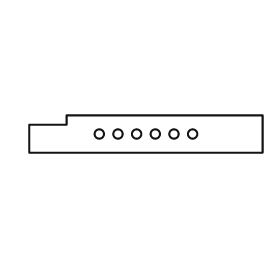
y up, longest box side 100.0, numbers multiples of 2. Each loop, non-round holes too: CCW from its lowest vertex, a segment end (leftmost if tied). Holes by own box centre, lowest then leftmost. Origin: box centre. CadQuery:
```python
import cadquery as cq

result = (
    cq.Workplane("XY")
    .moveTo(-50.0, -8.0)
    .lineTo(50.0, -8.0)
    .lineTo(50.0, 8.0)
    .lineTo(-34.0, 8.0)
    .lineTo(-34.0, 4.0)
    .lineTo(-50.0, 4.0)
    .close()
    .moveTo(-20.0, 0.0)
    .circle(2.0)
    .moveTo(-12.0, 0.0)
    .circle(2.0)
    .moveTo(-4.0, 0.0)
    .circle(2.0)
    .moveTo(4.0, 0.0)
    .circle(2.0)
    .moveTo(12.0, 0.0)
    .circle(2.0)
    .moveTo(20.0, 0.0)
    .circle(2.0)
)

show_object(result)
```